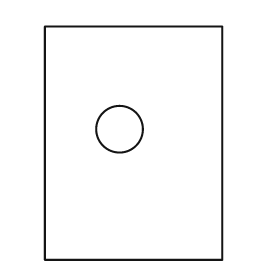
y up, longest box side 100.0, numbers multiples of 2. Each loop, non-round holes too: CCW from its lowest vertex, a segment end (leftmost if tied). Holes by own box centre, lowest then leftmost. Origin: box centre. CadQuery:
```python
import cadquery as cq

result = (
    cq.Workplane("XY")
    .moveTo(-38.0, -50.0)
    .lineTo(38.0, -50.0)
    .lineTo(38.0, 50.0)
    .lineTo(-38.0, 50.0)
    .close()
    .moveTo(-6.0, 6.0)
    .circle(10.0)
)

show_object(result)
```